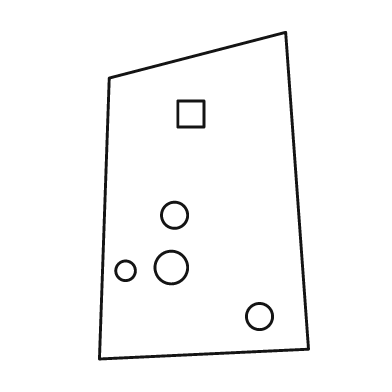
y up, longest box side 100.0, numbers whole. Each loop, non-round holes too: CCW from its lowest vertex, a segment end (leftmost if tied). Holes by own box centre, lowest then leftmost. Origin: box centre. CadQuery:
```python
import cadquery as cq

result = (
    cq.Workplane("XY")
    .moveTo(-32.0, -50.0)
    .lineTo(32.0, -47.0)
    .lineTo(25.0, 50.0)
    .lineTo(-29.0, 36.0)
    .close()
    .moveTo(17.0, -37.0)
    .circle(4.0)
    .moveTo(-24.0, -23.0)
    .circle(3.0)
    .moveTo(-10.0, -22.0)
    .circle(5.0)
    .moveTo(-9.0, -6.0)
    .circle(4.0)
    .moveTo(-8.0, 21.0)
    .lineTo(0.0, 21.0)
    .lineTo(0.0, 29.0)
    .lineTo(-8.0, 29.0)
    .close()
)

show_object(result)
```